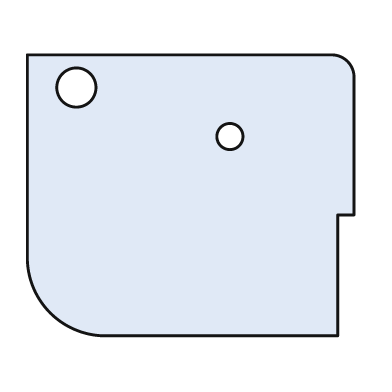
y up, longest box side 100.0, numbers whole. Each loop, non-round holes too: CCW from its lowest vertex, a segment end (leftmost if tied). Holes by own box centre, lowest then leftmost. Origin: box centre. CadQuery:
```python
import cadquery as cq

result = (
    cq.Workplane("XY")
    .moveTo(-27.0, -43.0)
    .lineTo(45.0, -43.0)
    .lineTo(45.0, -6.0)
    .lineTo(50.0, -6.0)
    .lineTo(50.0, 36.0)
    .threePointArc((48.0, 41.0), (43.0, 43.0))
    .lineTo(-50.0, 43.0)
    .lineTo(-50.0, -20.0)
    .threePointArc((-43.0, -36.0), (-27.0, -43.0))
    .close()
    .moveTo(12.0, 18.0)
    .circle(4.0)
    .moveTo(-35.0, 33.0)
    .circle(6.0)
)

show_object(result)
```